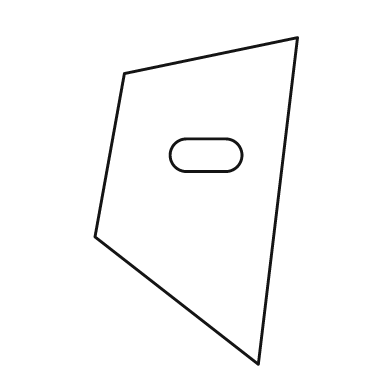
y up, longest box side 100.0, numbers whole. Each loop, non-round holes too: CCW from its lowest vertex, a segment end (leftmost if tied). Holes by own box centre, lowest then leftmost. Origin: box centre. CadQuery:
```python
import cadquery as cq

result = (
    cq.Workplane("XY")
    .moveTo(19.0, -50.0)
    .lineTo(31.0, 50.0)
    .lineTo(-22.0, 39.0)
    .lineTo(-31.0, -11.0)
    .close()
    .moveTo(-3.0, 9.0)
    .lineTo(9.0, 9.0)
    .threePointArc((14.0, 14.0), (9.0, 19.0))
    .lineTo(-3.0, 19.0)
    .threePointArc((-8.0, 14.0), (-3.0, 9.0))
    .close()
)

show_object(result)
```